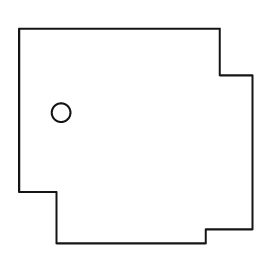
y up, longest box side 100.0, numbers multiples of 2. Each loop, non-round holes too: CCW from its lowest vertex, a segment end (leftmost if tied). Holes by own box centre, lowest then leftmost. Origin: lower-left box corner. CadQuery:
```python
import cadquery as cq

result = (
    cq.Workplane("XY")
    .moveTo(16.0, 0.0)
    .lineTo(80.0, 0.0)
    .lineTo(80.0, 6.0)
    .lineTo(100.0, 6.0)
    .lineTo(100.0, 72.0)
    .lineTo(86.0, 72.0)
    .lineTo(86.0, 92.0)
    .lineTo(0.0, 92.0)
    .lineTo(0.0, 22.0)
    .lineTo(16.0, 22.0)
    .close()
    .moveTo(18.0, 56.0)
    .circle(4.0)
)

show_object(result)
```